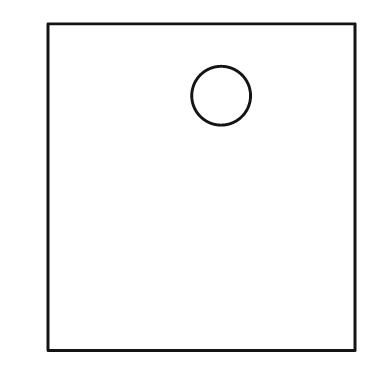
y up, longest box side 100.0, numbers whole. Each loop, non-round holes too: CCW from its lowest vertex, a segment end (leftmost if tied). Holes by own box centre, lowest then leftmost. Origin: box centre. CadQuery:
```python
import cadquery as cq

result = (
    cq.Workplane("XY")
    .moveTo(-47.0, -50.0)
    .lineTo(47.0, -50.0)
    .lineTo(47.0, 50.0)
    .lineTo(-47.0, 50.0)
    .close()
    .moveTo(6.0, 28.0)
    .circle(9.0)
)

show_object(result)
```